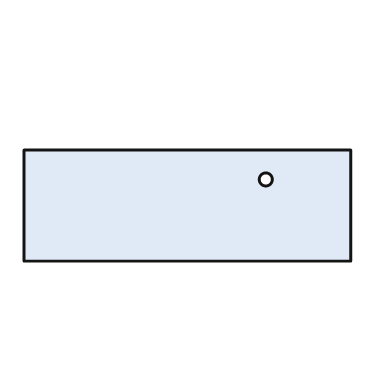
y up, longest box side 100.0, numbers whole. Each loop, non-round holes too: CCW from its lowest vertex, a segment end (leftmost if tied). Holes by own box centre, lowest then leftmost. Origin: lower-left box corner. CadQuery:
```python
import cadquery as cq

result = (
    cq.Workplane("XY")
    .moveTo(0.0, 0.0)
    .lineTo(100.0, 0.0)
    .lineTo(100.0, 34.0)
    .lineTo(0.0, 34.0)
    .close()
    .moveTo(74.0, 25.0)
    .circle(2.0)
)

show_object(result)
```